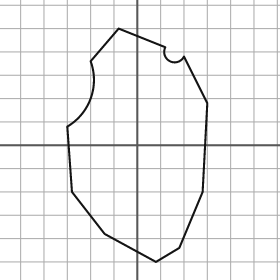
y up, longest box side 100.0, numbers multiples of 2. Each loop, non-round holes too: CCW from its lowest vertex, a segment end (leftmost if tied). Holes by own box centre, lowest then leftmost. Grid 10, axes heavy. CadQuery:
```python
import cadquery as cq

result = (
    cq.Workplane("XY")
    .moveTo(8.0, -50.0)
    .lineTo(18.0, -44.0)
    .lineTo(28.0, -20.0)
    .lineTo(30.0, 18.0)
    .lineTo(20.0, 38.0)
    .threePointArc((14.0, 36.0), (12.0, 42.0))
    .lineTo(-8.0, 50.0)
    .lineTo(-20.0, 36.0)
    .threePointArc((-20.0, 20.0), (-30.0, 8.0))
    .lineTo(-28.0, -20.0)
    .lineTo(-14.0, -38.0)
    .close()
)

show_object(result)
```